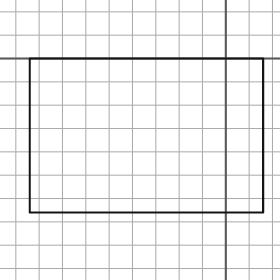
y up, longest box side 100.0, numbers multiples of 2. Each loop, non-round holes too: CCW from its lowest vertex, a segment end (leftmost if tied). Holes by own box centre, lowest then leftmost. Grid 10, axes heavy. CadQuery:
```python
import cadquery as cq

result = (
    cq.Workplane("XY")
    .moveTo(-84.0, -66.0)
    .lineTo(16.0, -66.0)
    .lineTo(16.0, 0.0)
    .lineTo(-84.0, 0.0)
    .close()
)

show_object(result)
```